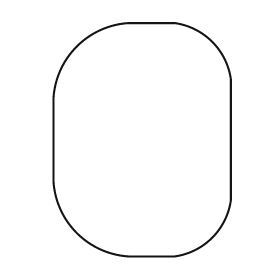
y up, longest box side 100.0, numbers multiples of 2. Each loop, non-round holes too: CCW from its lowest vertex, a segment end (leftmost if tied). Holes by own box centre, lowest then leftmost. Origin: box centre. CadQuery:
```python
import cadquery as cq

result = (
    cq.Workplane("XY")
    .moveTo(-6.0, -50.0)
    .lineTo(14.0, -50.0)
    .threePointArc((30.0, -42.0), (38.0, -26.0))
    .lineTo(38.0, 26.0)
    .threePointArc((30.0, 42.0), (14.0, 50.0))
    .lineTo(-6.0, 50.0)
    .threePointArc((-28.0, 40.0), (-38.0, 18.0))
    .lineTo(-38.0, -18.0)
    .threePointArc((-28.0, -40.0), (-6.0, -50.0))
    .close()
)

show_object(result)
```